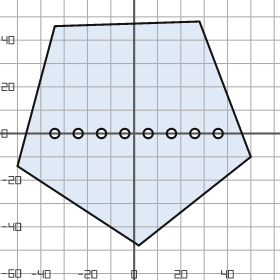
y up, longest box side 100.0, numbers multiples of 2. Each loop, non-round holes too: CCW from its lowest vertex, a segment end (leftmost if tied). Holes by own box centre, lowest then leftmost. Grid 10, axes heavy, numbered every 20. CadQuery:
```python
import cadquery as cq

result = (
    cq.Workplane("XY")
    .moveTo(2.0, -48.0)
    .lineTo(50.0, -10.0)
    .lineTo(28.0, 48.0)
    .lineTo(-34.0, 46.0)
    .lineTo(-50.0, -14.0)
    .close()
    .moveTo(-34.0, 0.0)
    .circle(2.0)
    .moveTo(-24.0, 0.0)
    .circle(2.0)
    .moveTo(-14.0, 0.0)
    .circle(2.0)
    .moveTo(-4.0, 0.0)
    .circle(2.0)
    .moveTo(6.0, 0.0)
    .circle(2.0)
    .moveTo(16.0, 0.0)
    .circle(2.0)
    .moveTo(26.0, 0.0)
    .circle(2.0)
    .moveTo(36.0, 0.0)
    .circle(2.0)
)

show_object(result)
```